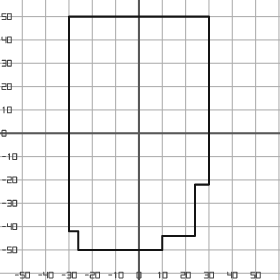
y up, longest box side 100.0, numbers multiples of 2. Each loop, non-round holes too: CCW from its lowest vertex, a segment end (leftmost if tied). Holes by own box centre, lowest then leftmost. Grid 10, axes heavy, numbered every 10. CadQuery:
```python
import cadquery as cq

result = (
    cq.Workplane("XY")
    .moveTo(-26.0, -50.0)
    .lineTo(10.0, -50.0)
    .lineTo(10.0, -44.0)
    .lineTo(24.0, -44.0)
    .lineTo(24.0, -22.0)
    .lineTo(30.0, -22.0)
    .lineTo(30.0, 50.0)
    .lineTo(-30.0, 50.0)
    .lineTo(-30.0, -42.0)
    .lineTo(-26.0, -42.0)
    .close()
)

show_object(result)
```